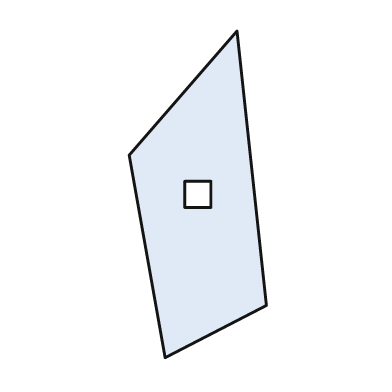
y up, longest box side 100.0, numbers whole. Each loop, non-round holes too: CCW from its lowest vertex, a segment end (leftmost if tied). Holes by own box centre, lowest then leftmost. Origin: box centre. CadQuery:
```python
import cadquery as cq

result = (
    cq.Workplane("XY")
    .moveTo(-10.0, -50.0)
    .lineTo(21.0, -34.0)
    .lineTo(12.0, 50.0)
    .lineTo(-21.0, 12.0)
    .close()
    .moveTo(-4.0, -4.0)
    .lineTo(4.0, -4.0)
    .lineTo(4.0, 4.0)
    .lineTo(-4.0, 4.0)
    .close()
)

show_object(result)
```